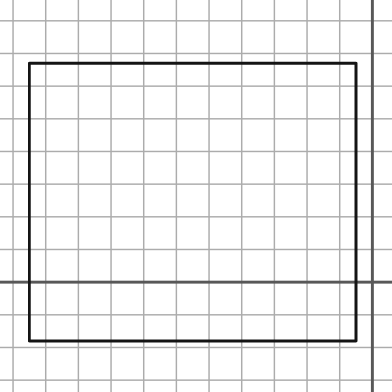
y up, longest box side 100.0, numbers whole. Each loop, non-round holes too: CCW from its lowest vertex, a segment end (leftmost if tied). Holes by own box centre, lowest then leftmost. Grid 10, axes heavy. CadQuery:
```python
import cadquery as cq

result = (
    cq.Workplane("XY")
    .moveTo(-105.0, -18.0)
    .lineTo(-5.0, -18.0)
    .lineTo(-5.0, 67.0)
    .lineTo(-105.0, 67.0)
    .close()
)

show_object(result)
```